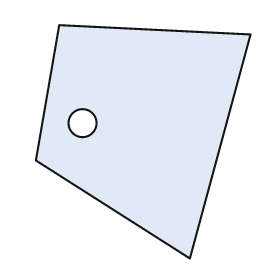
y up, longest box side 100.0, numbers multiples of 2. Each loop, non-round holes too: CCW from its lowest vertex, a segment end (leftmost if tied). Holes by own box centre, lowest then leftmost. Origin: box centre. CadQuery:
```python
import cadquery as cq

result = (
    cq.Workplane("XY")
    .moveTo(20.0, -50.0)
    .lineTo(46.0, 46.0)
    .lineTo(-36.0, 50.0)
    .lineTo(-46.0, -8.0)
    .close()
    .moveTo(-26.0, 8.0)
    .circle(6.0)
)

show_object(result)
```